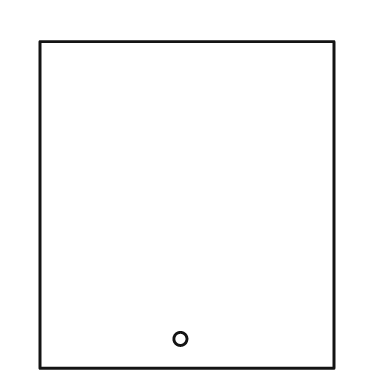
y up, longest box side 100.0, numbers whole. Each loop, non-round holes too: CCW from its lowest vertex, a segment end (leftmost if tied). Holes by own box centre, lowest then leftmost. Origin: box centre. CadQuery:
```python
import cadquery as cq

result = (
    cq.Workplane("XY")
    .moveTo(-45.0, -50.0)
    .lineTo(45.0, -50.0)
    .lineTo(45.0, 50.0)
    .lineTo(-45.0, 50.0)
    .close()
    .moveTo(-2.0, -41.0)
    .circle(2.0)
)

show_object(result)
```